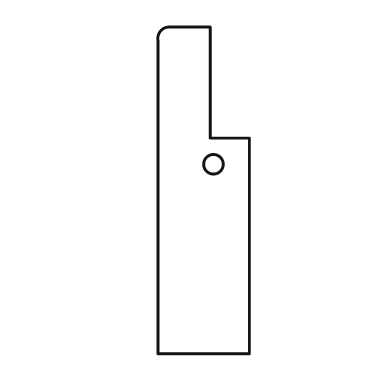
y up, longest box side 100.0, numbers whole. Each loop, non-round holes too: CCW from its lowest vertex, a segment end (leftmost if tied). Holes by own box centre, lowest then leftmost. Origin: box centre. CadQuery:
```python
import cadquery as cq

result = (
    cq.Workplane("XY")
    .moveTo(-14.0, -50.0)
    .lineTo(14.0, -50.0)
    .lineTo(14.0, 16.0)
    .lineTo(2.0, 16.0)
    .lineTo(2.0, 50.0)
    .lineTo(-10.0, 50.0)
    .threePointArc((-13.0, 49.0), (-14.0, 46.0))
    .close()
    .moveTo(3.0, 8.0)
    .circle(3.0)
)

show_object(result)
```